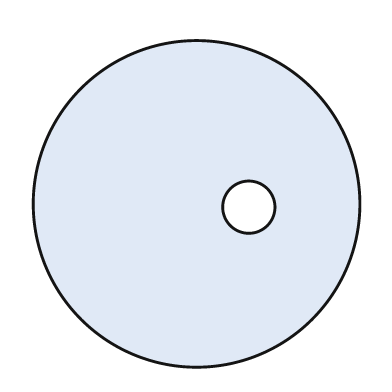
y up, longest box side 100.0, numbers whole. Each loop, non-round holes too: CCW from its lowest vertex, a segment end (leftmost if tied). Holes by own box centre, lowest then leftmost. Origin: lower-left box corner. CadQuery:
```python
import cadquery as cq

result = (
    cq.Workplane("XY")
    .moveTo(50.0, 50.0)
    .circle(50.0)
    .moveTo(66.0, 49.0)
    .circle(8.0)
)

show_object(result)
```